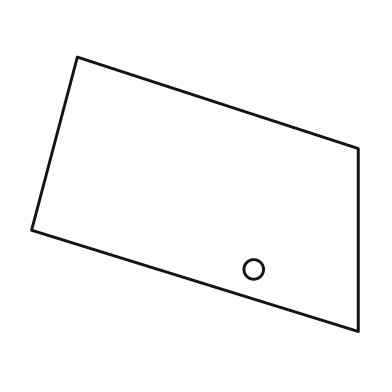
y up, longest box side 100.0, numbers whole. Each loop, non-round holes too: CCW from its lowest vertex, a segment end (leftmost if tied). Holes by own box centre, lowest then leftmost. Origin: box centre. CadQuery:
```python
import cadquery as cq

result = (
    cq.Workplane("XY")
    .moveTo(50.0, -42.0)
    .lineTo(50.0, 14.0)
    .lineTo(-36.0, 42.0)
    .lineTo(-50.0, -11.0)
    .close()
    .moveTo(18.0, -23.0)
    .circle(3.0)
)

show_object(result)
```